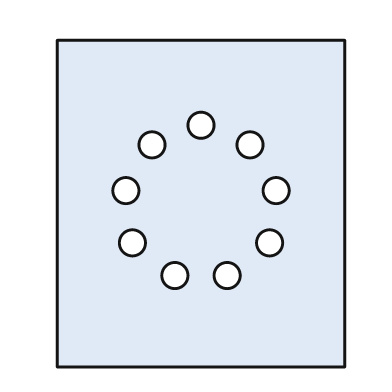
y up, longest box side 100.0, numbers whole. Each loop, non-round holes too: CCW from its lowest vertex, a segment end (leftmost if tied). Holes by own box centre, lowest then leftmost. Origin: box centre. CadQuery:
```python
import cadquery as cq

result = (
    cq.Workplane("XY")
    .moveTo(-44.0, -50.0)
    .lineTo(44.0, -50.0)
    .lineTo(44.0, 50.0)
    .lineTo(-44.0, 50.0)
    .close()
    .moveTo(-8.0, -22.0)
    .circle(4.0)
    .moveTo(8.0, -22.0)
    .circle(4.0)
    .moveTo(-21.0, -12.0)
    .circle(4.0)
    .moveTo(21.0, -12.0)
    .circle(4.0)
    .moveTo(-23.0, 4.0)
    .circle(4.0)
    .moveTo(23.0, 4.0)
    .circle(4.0)
    .moveTo(-15.0, 18.0)
    .circle(4.0)
    .moveTo(15.0, 18.0)
    .circle(4.0)
    .moveTo(0.0, 24.0)
    .circle(4.0)
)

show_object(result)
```